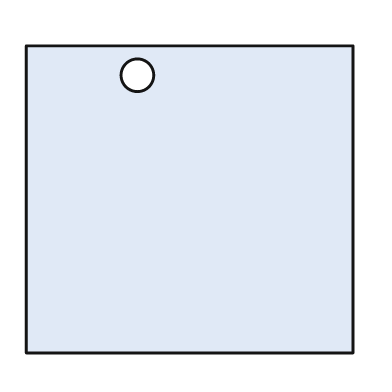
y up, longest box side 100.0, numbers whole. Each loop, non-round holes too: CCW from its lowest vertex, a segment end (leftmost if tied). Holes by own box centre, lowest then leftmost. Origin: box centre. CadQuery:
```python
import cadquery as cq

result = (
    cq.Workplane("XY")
    .moveTo(-50.0, -47.0)
    .lineTo(50.0, -47.0)
    .lineTo(50.0, 47.0)
    .lineTo(-50.0, 47.0)
    .close()
    .moveTo(-16.0, 38.0)
    .circle(5.0)
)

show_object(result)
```